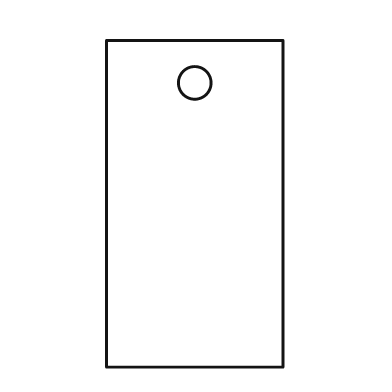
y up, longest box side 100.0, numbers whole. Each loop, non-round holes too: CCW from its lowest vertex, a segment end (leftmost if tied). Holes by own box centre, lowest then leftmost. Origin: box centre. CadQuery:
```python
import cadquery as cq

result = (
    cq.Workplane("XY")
    .moveTo(-27.0, -50.0)
    .lineTo(27.0, -50.0)
    .lineTo(27.0, 50.0)
    .lineTo(-27.0, 50.0)
    .close()
    .moveTo(0.0, 37.0)
    .circle(5.0)
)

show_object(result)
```